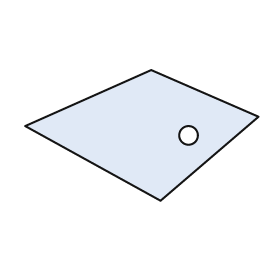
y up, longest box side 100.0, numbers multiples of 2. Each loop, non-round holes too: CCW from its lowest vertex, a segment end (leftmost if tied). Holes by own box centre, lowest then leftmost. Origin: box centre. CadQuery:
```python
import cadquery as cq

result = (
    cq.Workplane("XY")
    .moveTo(8.0, -28.0)
    .lineTo(50.0, 8.0)
    .lineTo(4.0, 28.0)
    .lineTo(-50.0, 4.0)
    .close()
    .moveTo(20.0, 0.0)
    .circle(4.0)
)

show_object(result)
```